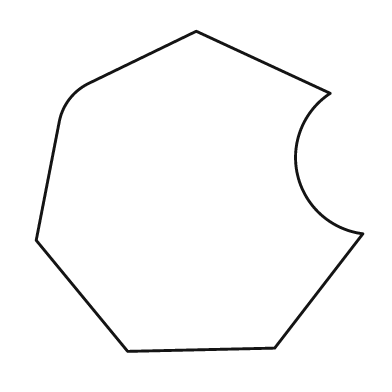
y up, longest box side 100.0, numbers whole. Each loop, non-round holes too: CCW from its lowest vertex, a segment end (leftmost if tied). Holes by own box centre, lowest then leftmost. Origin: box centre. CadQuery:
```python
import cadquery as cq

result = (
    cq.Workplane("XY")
    .moveTo(-22.0, -49.0)
    .lineTo(23.0, -48.0)
    .lineTo(50.0, -13.0)
    .threePointArc((30.0, 5.0), (40.0, 30.0))
    .lineTo(-1.0, 49.0)
    .lineTo(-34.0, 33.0)
    .threePointArc((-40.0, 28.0), (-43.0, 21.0))
    .lineTo(-50.0, -15.0)
    .close()
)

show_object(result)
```